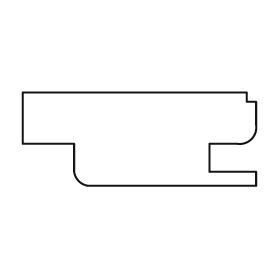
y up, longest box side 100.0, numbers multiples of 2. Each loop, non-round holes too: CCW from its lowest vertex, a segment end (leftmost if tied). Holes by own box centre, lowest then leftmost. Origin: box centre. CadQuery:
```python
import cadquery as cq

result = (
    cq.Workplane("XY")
    .moveTo(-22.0, -20.0)
    .lineTo(50.0, -20.0)
    .lineTo(50.0, -14.0)
    .lineTo(30.0, -14.0)
    .lineTo(30.0, -2.0)
    .lineTo(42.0, -2.0)
    .threePointArc((48.0, 0.0), (50.0, 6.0))
    .lineTo(50.0, 16.0)
    .lineTo(46.0, 16.0)
    .lineTo(46.0, 20.0)
    .lineTo(-50.0, 20.0)
    .lineTo(-50.0, -2.0)
    .lineTo(-28.0, -2.0)
    .lineTo(-28.0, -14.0)
    .threePointArc((-26.0, -18.0), (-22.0, -20.0))
    .close()
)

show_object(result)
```